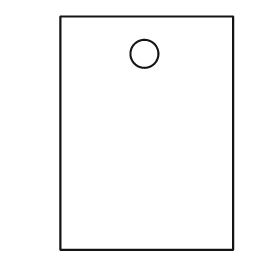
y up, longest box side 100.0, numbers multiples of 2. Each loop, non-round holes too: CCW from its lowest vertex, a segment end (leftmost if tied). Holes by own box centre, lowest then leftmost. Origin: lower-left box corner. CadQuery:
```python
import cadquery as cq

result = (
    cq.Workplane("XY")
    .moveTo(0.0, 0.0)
    .lineTo(74.0, 0.0)
    .lineTo(74.0, 100.0)
    .lineTo(0.0, 100.0)
    .close()
    .moveTo(36.0, 84.0)
    .circle(6.0)
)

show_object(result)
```